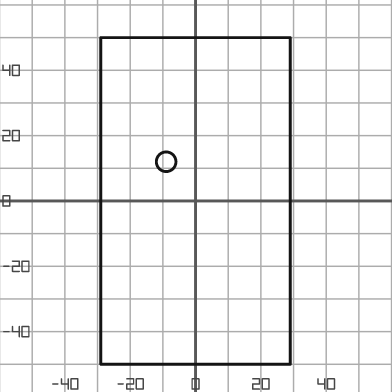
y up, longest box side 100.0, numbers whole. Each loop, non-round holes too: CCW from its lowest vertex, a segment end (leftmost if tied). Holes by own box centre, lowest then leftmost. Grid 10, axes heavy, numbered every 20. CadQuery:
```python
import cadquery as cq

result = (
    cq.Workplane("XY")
    .moveTo(-29.0, -50.0)
    .lineTo(29.0, -50.0)
    .lineTo(29.0, 50.0)
    .lineTo(-29.0, 50.0)
    .close()
    .moveTo(-9.0, 12.0)
    .circle(3.0)
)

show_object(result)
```